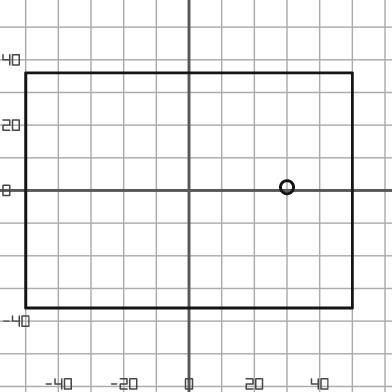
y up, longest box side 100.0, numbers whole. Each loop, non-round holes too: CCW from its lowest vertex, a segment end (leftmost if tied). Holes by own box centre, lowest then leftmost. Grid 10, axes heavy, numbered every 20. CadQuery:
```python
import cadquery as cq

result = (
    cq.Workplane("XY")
    .moveTo(-50.0, -36.0)
    .lineTo(50.0, -36.0)
    .lineTo(50.0, 36.0)
    .lineTo(-50.0, 36.0)
    .close()
    .moveTo(30.0, 1.0)
    .circle(2.0)
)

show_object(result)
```